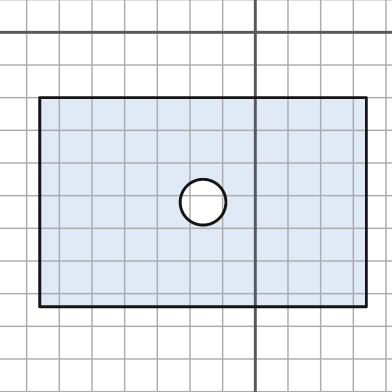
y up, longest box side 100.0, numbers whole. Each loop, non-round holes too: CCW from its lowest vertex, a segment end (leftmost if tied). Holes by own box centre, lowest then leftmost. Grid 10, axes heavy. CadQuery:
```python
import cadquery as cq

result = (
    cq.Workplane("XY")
    .moveTo(-66.0, -84.0)
    .lineTo(34.0, -84.0)
    .lineTo(34.0, -20.0)
    .lineTo(-66.0, -20.0)
    .close()
    .moveTo(-16.0, -52.0)
    .circle(7.0)
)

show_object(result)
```